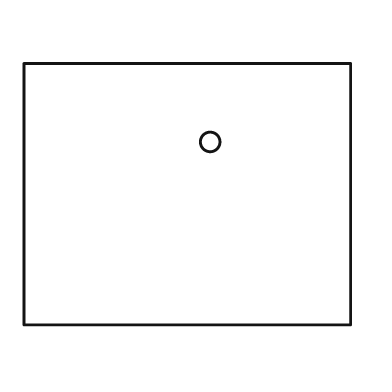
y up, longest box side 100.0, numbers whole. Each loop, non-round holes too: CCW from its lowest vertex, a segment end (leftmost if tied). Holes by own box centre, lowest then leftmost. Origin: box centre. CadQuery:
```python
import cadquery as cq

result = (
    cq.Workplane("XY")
    .moveTo(-50.0, -40.0)
    .lineTo(50.0, -40.0)
    .lineTo(50.0, 40.0)
    .lineTo(-50.0, 40.0)
    .close()
    .moveTo(7.0, 16.0)
    .circle(3.0)
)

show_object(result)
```